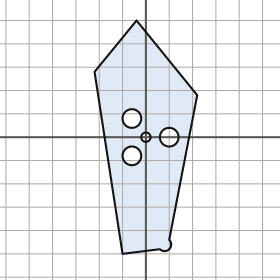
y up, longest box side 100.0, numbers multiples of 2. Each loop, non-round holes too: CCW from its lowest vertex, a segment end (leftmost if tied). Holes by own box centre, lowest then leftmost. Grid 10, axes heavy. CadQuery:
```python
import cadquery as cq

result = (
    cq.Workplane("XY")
    .moveTo(-10.0, -50.0)
    .lineTo(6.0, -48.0)
    .threePointArc((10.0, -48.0), (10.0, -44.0))
    .lineTo(22.0, 18.0)
    .lineTo(-4.0, 50.0)
    .lineTo(-22.0, 28.0)
    .close()
    .moveTo(-6.0, -8.0)
    .circle(4.0)
    .moveTo(0.0, 0.0)
    .circle(2.0)
    .moveTo(10.0, 0.0)
    .circle(4.0)
    .moveTo(-6.0, 8.0)
    .circle(4.0)
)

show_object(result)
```